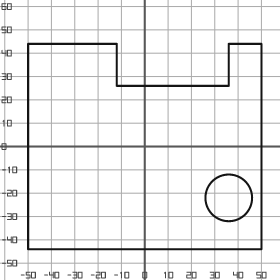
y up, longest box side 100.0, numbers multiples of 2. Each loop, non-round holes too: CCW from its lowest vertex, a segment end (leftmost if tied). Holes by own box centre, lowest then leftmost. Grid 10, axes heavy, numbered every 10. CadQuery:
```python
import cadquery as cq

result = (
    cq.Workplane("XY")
    .moveTo(-50.0, -44.0)
    .lineTo(50.0, -44.0)
    .lineTo(50.0, 44.0)
    .lineTo(36.0, 44.0)
    .lineTo(36.0, 26.0)
    .lineTo(-12.0, 26.0)
    .lineTo(-12.0, 44.0)
    .lineTo(-50.0, 44.0)
    .close()
    .moveTo(36.0, -22.0)
    .circle(10.0)
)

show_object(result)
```